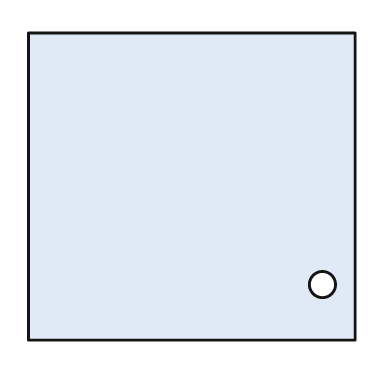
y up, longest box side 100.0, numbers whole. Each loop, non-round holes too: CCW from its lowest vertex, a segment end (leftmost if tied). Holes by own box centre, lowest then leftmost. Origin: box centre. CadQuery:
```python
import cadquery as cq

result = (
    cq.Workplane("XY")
    .moveTo(-50.0, -47.0)
    .lineTo(50.0, -47.0)
    .lineTo(50.0, 47.0)
    .lineTo(-50.0, 47.0)
    .close()
    .moveTo(40.0, -30.0)
    .circle(4.0)
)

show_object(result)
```